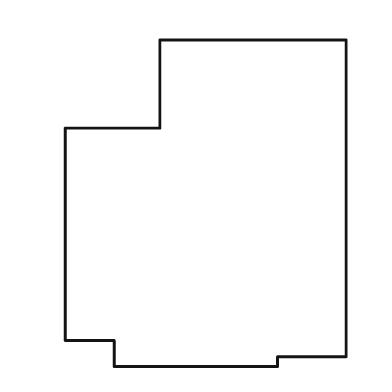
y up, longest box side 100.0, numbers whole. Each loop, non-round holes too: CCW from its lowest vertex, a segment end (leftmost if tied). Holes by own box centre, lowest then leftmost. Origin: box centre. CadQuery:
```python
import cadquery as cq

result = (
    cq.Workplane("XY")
    .moveTo(-28.0, -50.0)
    .lineTo(22.0, -50.0)
    .lineTo(22.0, -47.0)
    .lineTo(43.0, -47.0)
    .lineTo(43.0, 50.0)
    .lineTo(-14.0, 50.0)
    .lineTo(-14.0, 23.0)
    .lineTo(-43.0, 23.0)
    .lineTo(-43.0, -42.0)
    .lineTo(-28.0, -42.0)
    .close()
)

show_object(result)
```